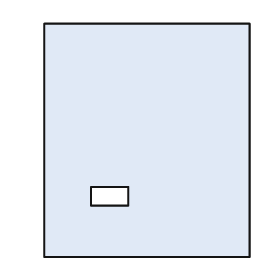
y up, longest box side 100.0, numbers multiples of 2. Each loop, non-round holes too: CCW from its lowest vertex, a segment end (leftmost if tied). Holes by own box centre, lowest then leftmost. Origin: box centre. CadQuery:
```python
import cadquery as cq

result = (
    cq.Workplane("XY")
    .moveTo(-44.0, -50.0)
    .lineTo(44.0, -50.0)
    .lineTo(44.0, 50.0)
    .lineTo(-44.0, 50.0)
    .close()
    .moveTo(-24.0, -28.0)
    .lineTo(-8.0, -28.0)
    .lineTo(-8.0, -20.0)
    .lineTo(-24.0, -20.0)
    .close()
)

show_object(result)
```